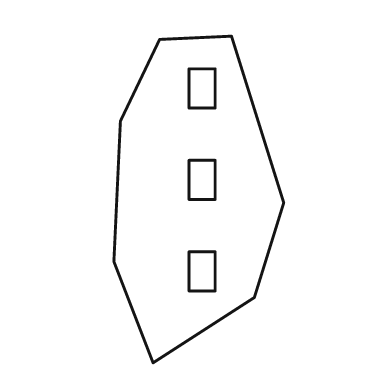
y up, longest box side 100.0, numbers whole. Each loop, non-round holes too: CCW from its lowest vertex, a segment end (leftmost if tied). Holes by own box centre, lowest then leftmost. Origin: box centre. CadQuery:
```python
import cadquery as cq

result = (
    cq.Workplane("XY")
    .moveTo(-14.0, -50.0)
    .lineTo(17.0, -30.0)
    .lineTo(26.0, -1.0)
    .lineTo(10.0, 50.0)
    .lineTo(-12.0, 49.0)
    .lineTo(-24.0, 24.0)
    .lineTo(-26.0, -19.0)
    .close()
    .moveTo(-3.0, -28.0)
    .lineTo(5.0, -28.0)
    .lineTo(5.0, -16.0)
    .lineTo(-3.0, -16.0)
    .close()
    .moveTo(-3.0, 0.0)
    .lineTo(5.0, 0.0)
    .lineTo(5.0, 12.0)
    .lineTo(-3.0, 12.0)
    .close()
    .moveTo(-3.0, 28.0)
    .lineTo(5.0, 28.0)
    .lineTo(5.0, 40.0)
    .lineTo(-3.0, 40.0)
    .close()
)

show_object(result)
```